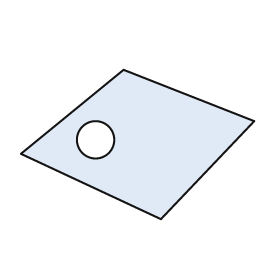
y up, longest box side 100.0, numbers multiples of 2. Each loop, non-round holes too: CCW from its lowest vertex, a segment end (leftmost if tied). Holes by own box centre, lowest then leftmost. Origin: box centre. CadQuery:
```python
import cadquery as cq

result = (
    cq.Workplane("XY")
    .moveTo(10.0, -32.0)
    .lineTo(50.0, 10.0)
    .lineTo(-6.0, 32.0)
    .lineTo(-50.0, -4.0)
    .close()
    .moveTo(-18.0, 2.0)
    .circle(8.0)
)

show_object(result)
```